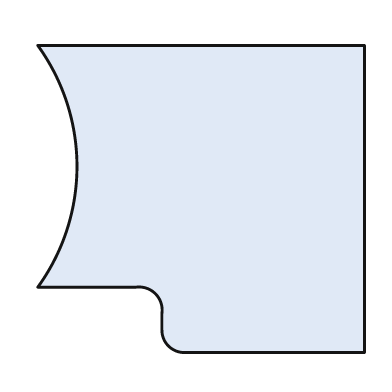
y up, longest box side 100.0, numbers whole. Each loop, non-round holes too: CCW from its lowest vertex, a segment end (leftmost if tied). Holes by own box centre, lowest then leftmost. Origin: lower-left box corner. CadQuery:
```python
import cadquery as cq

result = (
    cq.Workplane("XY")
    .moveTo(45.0, 0.0)
    .lineTo(100.0, 0.0)
    .lineTo(100.0, 94.0)
    .lineTo(0.0, 94.0)
    .threePointArc((12.0, 57.0), (0.0, 20.0))
    .lineTo(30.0, 20.0)
    .threePointArc((36.0, 18.0), (38.0, 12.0))
    .lineTo(38.0, 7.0)
    .threePointArc((40.0, 2.0), (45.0, 0.0))
    .close()
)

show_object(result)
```